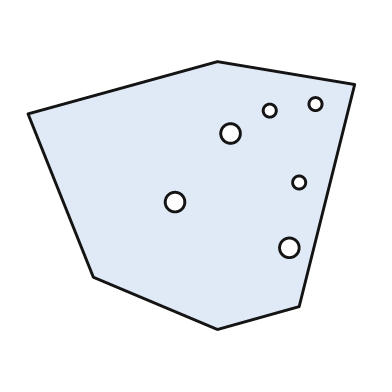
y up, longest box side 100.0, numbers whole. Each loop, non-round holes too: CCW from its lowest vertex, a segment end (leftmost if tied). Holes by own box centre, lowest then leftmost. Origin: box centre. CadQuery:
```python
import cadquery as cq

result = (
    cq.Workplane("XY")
    .moveTo(8.0, -41.0)
    .lineTo(33.0, -34.0)
    .lineTo(50.0, 34.0)
    .lineTo(8.0, 41.0)
    .lineTo(-50.0, 25.0)
    .lineTo(-30.0, -25.0)
    .close()
    .moveTo(30.0, -16.0)
    .circle(3.0)
    .moveTo(-5.0, -2.0)
    .circle(3.0)
    .moveTo(33.0, 4.0)
    .circle(2.0)
    .moveTo(12.0, 19.0)
    .circle(3.0)
    .moveTo(24.0, 26.0)
    .circle(2.0)
    .moveTo(38.0, 28.0)
    .circle(2.0)
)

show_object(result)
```